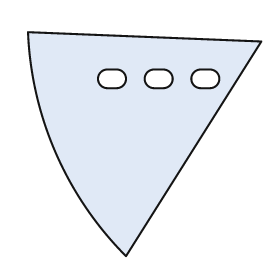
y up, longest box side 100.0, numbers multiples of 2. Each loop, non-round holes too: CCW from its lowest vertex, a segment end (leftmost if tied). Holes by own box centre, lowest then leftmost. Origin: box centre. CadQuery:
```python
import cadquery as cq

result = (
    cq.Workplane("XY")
    .moveTo(-8.0, -48.0)
    .lineTo(50.0, 44.0)
    .lineTo(-50.0, 48.0)
    .threePointArc((-38.0, -4.0), (-8.0, -48.0))
    .close()
    .moveTo(-16.0, 24.0)
    .lineTo(-12.0, 24.0)
    .threePointArc((-8.0, 28.0), (-12.0, 32.0))
    .lineTo(-16.0, 32.0)
    .threePointArc((-20.0, 28.0), (-16.0, 24.0))
    .close()
    .moveTo(4.0, 24.0)
    .lineTo(8.0, 24.0)
    .threePointArc((12.0, 28.0), (8.0, 32.0))
    .lineTo(4.0, 32.0)
    .threePointArc((0.0, 28.0), (4.0, 24.0))
    .close()
    .moveTo(24.0, 24.0)
    .lineTo(28.0, 24.0)
    .threePointArc((32.0, 28.0), (28.0, 32.0))
    .lineTo(24.0, 32.0)
    .threePointArc((20.0, 28.0), (24.0, 24.0))
    .close()
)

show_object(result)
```